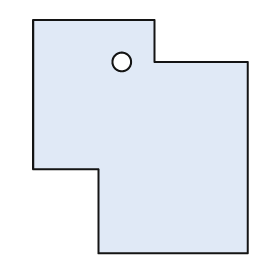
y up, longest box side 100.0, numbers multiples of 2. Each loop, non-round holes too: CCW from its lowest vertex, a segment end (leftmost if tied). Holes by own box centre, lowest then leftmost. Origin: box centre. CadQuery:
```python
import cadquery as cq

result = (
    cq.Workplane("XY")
    .moveTo(-18.0, -50.0)
    .lineTo(46.0, -50.0)
    .lineTo(46.0, 32.0)
    .lineTo(6.0, 32.0)
    .lineTo(6.0, 50.0)
    .lineTo(-46.0, 50.0)
    .lineTo(-46.0, -14.0)
    .lineTo(-18.0, -14.0)
    .close()
    .moveTo(-8.0, 32.0)
    .circle(4.0)
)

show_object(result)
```